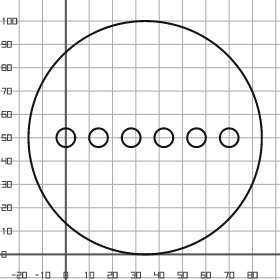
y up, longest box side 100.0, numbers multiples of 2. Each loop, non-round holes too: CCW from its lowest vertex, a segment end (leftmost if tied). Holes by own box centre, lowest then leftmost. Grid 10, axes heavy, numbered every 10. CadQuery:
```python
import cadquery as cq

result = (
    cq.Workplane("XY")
    .moveTo(34.0, 50.0)
    .circle(50.0)
    .moveTo(0.0, 50.0)
    .circle(4.0)
    .moveTo(14.0, 50.0)
    .circle(4.0)
    .moveTo(28.0, 50.0)
    .circle(4.0)
    .moveTo(42.0, 50.0)
    .circle(4.0)
    .moveTo(56.0, 50.0)
    .circle(4.0)
    .moveTo(70.0, 50.0)
    .circle(4.0)
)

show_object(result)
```